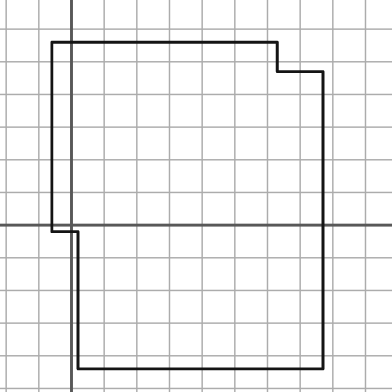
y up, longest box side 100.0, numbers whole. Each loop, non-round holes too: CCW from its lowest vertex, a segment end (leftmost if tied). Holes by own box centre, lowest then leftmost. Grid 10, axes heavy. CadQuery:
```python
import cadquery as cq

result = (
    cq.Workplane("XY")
    .moveTo(2.0, -44.0)
    .lineTo(77.0, -44.0)
    .lineTo(77.0, 47.0)
    .lineTo(63.0, 47.0)
    .lineTo(63.0, 56.0)
    .lineTo(-6.0, 56.0)
    .lineTo(-6.0, -2.0)
    .lineTo(2.0, -2.0)
    .close()
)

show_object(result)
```